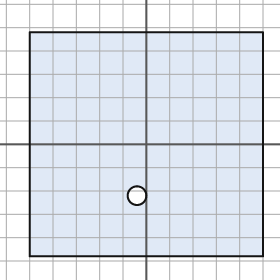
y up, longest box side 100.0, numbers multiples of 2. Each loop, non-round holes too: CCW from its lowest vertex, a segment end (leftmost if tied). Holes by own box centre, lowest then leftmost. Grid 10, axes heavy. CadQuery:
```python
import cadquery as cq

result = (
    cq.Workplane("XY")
    .moveTo(-50.0, -48.0)
    .lineTo(50.0, -48.0)
    .lineTo(50.0, 48.0)
    .lineTo(-50.0, 48.0)
    .close()
    .moveTo(-4.0, -22.0)
    .circle(4.0)
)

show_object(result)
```